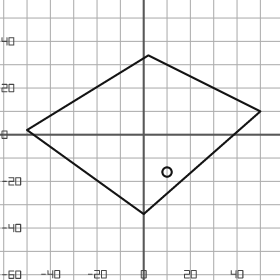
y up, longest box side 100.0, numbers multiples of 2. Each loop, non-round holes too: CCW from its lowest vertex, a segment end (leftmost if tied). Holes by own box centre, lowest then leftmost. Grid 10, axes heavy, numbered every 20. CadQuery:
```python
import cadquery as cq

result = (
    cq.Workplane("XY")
    .moveTo(0.0, -34.0)
    .lineTo(50.0, 10.0)
    .lineTo(2.0, 34.0)
    .lineTo(-50.0, 2.0)
    .close()
    .moveTo(10.0, -16.0)
    .circle(2.0)
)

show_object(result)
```